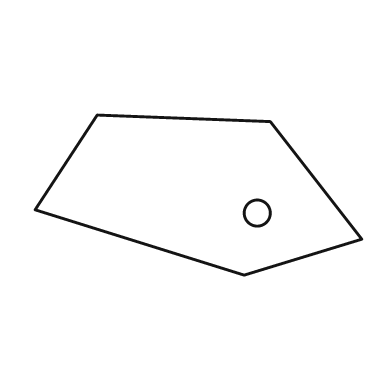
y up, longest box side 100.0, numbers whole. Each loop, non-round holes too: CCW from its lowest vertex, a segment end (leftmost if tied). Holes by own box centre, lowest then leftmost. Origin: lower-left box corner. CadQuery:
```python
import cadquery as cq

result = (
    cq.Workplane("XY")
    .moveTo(64.0, 0.0)
    .lineTo(100.0, 11.0)
    .lineTo(72.0, 47.0)
    .lineTo(19.0, 49.0)
    .lineTo(0.0, 20.0)
    .close()
    .moveTo(68.0, 19.0)
    .circle(4.0)
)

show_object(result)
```